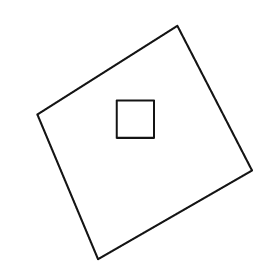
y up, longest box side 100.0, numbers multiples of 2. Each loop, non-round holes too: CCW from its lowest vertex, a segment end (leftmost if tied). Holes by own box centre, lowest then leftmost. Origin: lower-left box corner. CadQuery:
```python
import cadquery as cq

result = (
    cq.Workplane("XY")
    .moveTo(26.0, 0.0)
    .lineTo(92.0, 38.0)
    .lineTo(60.0, 100.0)
    .lineTo(0.0, 62.0)
    .close()
    .moveTo(34.0, 52.0)
    .lineTo(50.0, 52.0)
    .lineTo(50.0, 68.0)
    .lineTo(34.0, 68.0)
    .close()
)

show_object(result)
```